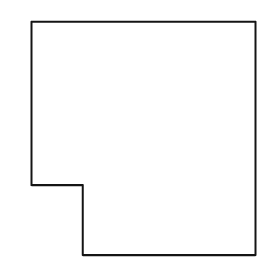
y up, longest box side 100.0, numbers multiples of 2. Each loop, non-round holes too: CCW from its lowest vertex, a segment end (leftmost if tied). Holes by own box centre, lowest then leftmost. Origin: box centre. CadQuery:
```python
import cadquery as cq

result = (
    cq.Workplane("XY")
    .moveTo(-26.0, -50.0)
    .lineTo(48.0, -50.0)
    .lineTo(48.0, 50.0)
    .lineTo(-48.0, 50.0)
    .lineTo(-48.0, -20.0)
    .lineTo(-26.0, -20.0)
    .close()
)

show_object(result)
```